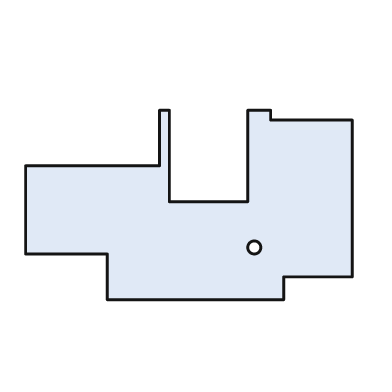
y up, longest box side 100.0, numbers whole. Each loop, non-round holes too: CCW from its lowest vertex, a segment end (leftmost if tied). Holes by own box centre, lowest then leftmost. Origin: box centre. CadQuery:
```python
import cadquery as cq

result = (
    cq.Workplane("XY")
    .moveTo(-25.0, -29.0)
    .lineTo(29.0, -29.0)
    .lineTo(29.0, -22.0)
    .lineTo(50.0, -22.0)
    .lineTo(50.0, 26.0)
    .lineTo(25.0, 26.0)
    .lineTo(25.0, 29.0)
    .lineTo(18.0, 29.0)
    .lineTo(18.0, 1.0)
    .lineTo(-6.0, 1.0)
    .lineTo(-6.0, 29.0)
    .lineTo(-9.0, 29.0)
    .lineTo(-9.0, 12.0)
    .lineTo(-50.0, 12.0)
    .lineTo(-50.0, -15.0)
    .lineTo(-25.0, -15.0)
    .close()
    .moveTo(20.0, -13.0)
    .circle(2.0)
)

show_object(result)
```